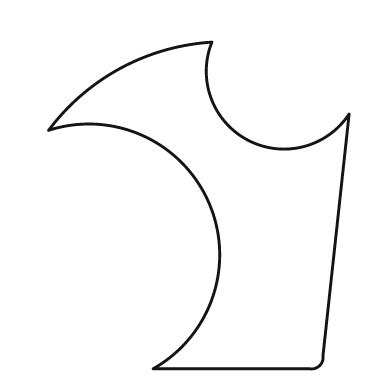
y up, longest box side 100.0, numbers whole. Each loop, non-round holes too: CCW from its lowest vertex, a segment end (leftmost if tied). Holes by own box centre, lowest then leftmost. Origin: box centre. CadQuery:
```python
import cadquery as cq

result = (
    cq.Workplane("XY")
    .moveTo(-14.0, -50.0)
    .lineTo(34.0, -50.0)
    .threePointArc((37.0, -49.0), (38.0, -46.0))
    .lineTo(46.0, 28.0)
    .threePointArc((15.0, 20.0), (4.0, 50.0))
    .threePointArc((-24.0, 42.0), (-46.0, 23.0))
    .threePointArc((3.0, 1.0), (-14.0, -50.0))
    .close()
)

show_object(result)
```